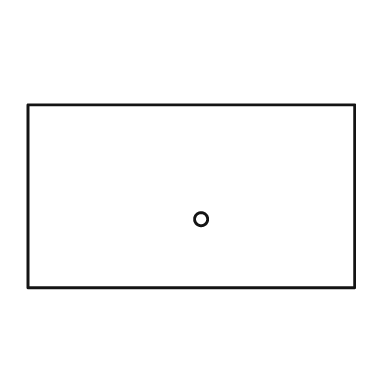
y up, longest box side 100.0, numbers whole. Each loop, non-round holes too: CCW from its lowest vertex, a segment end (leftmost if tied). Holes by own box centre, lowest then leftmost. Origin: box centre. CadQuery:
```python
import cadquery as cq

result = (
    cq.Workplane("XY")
    .moveTo(-50.0, -28.0)
    .lineTo(50.0, -28.0)
    .lineTo(50.0, 28.0)
    .lineTo(-50.0, 28.0)
    .close()
    .moveTo(3.0, -7.0)
    .circle(2.0)
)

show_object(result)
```